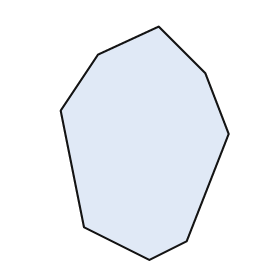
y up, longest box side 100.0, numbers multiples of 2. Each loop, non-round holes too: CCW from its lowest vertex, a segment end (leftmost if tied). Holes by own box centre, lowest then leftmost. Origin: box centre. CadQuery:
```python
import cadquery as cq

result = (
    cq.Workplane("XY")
    .moveTo(2.0, -50.0)
    .lineTo(18.0, -42.0)
    .lineTo(36.0, 4.0)
    .lineTo(26.0, 30.0)
    .lineTo(6.0, 50.0)
    .lineTo(-20.0, 38.0)
    .lineTo(-36.0, 14.0)
    .lineTo(-26.0, -36.0)
    .close()
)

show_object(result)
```